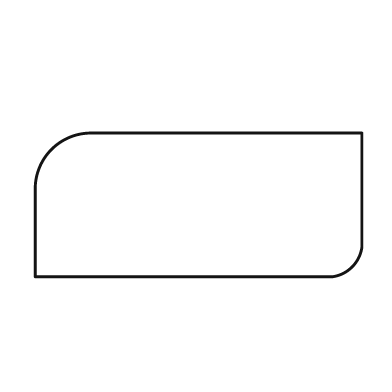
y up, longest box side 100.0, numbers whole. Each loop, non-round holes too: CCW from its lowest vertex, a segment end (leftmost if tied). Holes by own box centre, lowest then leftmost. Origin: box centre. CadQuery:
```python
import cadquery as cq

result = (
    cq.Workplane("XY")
    .moveTo(-50.0, -22.0)
    .lineTo(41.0, -22.0)
    .threePointArc((47.0, -19.0), (50.0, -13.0))
    .lineTo(50.0, 22.0)
    .lineTo(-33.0, 22.0)
    .threePointArc((-45.0, 17.0), (-50.0, 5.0))
    .close()
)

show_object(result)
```